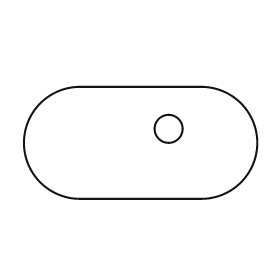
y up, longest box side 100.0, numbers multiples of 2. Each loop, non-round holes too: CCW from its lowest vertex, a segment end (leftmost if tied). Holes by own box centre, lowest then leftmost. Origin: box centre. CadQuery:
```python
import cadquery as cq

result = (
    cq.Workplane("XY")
    .moveTo(-26.0, -24.0)
    .lineTo(26.0, -24.0)
    .threePointArc((50.0, 0.0), (26.0, 24.0))
    .lineTo(-26.0, 24.0)
    .threePointArc((-50.0, 0.0), (-26.0, -24.0))
    .close()
    .moveTo(12.0, 6.0)
    .circle(6.0)
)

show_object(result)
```